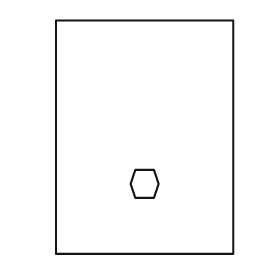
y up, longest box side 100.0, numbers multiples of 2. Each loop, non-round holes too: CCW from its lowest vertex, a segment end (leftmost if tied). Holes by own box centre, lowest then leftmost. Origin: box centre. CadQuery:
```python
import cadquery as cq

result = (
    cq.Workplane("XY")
    .moveTo(-38.0, -50.0)
    .lineTo(38.0, -50.0)
    .lineTo(38.0, 50.0)
    .lineTo(-38.0, 50.0)
    .close()
    .moveTo(-4.0, -26.0)
    .lineTo(4.0, -26.0)
    .lineTo(6.0, -20.0)
    .lineTo(4.0, -14.0)
    .lineTo(-4.0, -14.0)
    .lineTo(-6.0, -20.0)
    .close()
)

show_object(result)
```